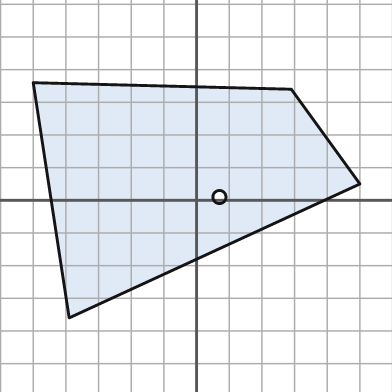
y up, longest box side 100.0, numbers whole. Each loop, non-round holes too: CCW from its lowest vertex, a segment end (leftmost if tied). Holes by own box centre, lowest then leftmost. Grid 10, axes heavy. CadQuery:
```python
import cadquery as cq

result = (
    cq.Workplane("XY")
    .moveTo(-39.0, -36.0)
    .lineTo(50.0, 5.0)
    .lineTo(29.0, 34.0)
    .lineTo(-50.0, 36.0)
    .close()
    .moveTo(7.0, 1.0)
    .circle(2.0)
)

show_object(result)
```